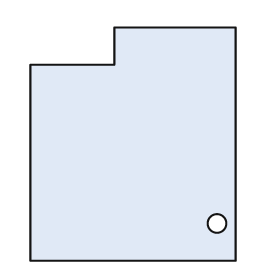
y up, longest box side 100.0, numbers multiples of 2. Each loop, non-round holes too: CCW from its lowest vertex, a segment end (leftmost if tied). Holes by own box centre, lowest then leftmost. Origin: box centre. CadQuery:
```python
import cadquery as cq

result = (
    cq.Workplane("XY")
    .moveTo(-44.0, -50.0)
    .lineTo(44.0, -50.0)
    .lineTo(44.0, 50.0)
    .lineTo(-8.0, 50.0)
    .lineTo(-8.0, 34.0)
    .lineTo(-44.0, 34.0)
    .close()
    .moveTo(36.0, -34.0)
    .circle(4.0)
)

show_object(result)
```